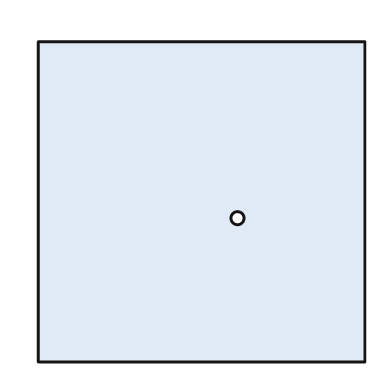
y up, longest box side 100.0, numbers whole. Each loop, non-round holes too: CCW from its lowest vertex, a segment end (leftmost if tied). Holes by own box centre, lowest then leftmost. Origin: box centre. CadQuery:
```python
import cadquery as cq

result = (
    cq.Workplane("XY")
    .moveTo(-50.0, -49.0)
    .lineTo(50.0, -49.0)
    .lineTo(50.0, 49.0)
    .lineTo(-50.0, 49.0)
    .close()
    .moveTo(11.0, -5.0)
    .circle(2.0)
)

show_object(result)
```